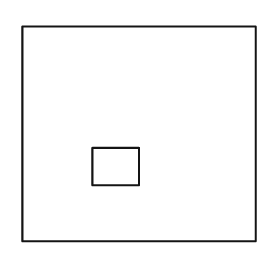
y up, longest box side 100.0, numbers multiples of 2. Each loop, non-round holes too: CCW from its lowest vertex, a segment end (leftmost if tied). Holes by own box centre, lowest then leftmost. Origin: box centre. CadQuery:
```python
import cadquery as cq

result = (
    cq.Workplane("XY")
    .moveTo(-50.0, -46.0)
    .lineTo(50.0, -46.0)
    .lineTo(50.0, 46.0)
    .lineTo(-50.0, 46.0)
    .close()
    .moveTo(-20.0, -22.0)
    .lineTo(0.0, -22.0)
    .lineTo(0.0, -6.0)
    .lineTo(-20.0, -6.0)
    .close()
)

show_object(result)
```